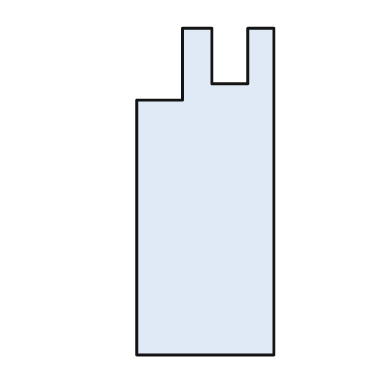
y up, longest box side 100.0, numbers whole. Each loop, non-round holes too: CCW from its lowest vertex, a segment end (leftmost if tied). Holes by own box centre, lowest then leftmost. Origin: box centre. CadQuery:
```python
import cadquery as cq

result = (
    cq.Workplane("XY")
    .moveTo(-21.0, -50.0)
    .lineTo(21.0, -50.0)
    .lineTo(21.0, 50.0)
    .lineTo(13.0, 50.0)
    .lineTo(13.0, 33.0)
    .lineTo(2.0, 33.0)
    .lineTo(2.0, 50.0)
    .lineTo(-7.0, 50.0)
    .lineTo(-7.0, 28.0)
    .lineTo(-21.0, 28.0)
    .close()
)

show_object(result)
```